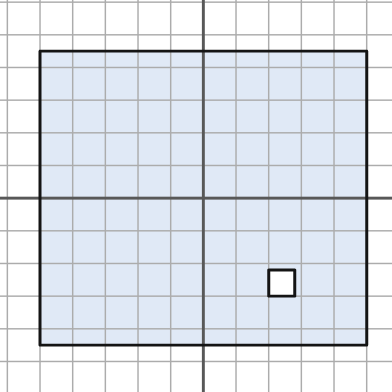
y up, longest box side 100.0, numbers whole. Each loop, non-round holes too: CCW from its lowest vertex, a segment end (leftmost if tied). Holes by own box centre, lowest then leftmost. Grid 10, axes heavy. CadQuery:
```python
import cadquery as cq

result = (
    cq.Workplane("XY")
    .moveTo(-50.0, -45.0)
    .lineTo(50.0, -45.0)
    .lineTo(50.0, 45.0)
    .lineTo(-50.0, 45.0)
    .close()
    .moveTo(20.0, -30.0)
    .lineTo(28.0, -30.0)
    .lineTo(28.0, -22.0)
    .lineTo(20.0, -22.0)
    .close()
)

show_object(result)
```